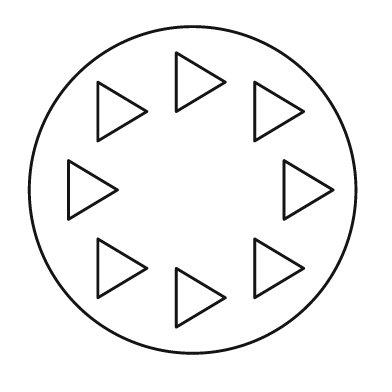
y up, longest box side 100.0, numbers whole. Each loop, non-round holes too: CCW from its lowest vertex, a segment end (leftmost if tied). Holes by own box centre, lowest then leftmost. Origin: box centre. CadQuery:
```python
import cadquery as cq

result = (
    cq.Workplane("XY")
    .moveTo(0.0, 0.0)
    .circle(50.0)
    .moveTo(-5.0, -42.0)
    .lineTo(10.0, -33.0)
    .lineTo(-5.0, -24.0)
    .close()
    .moveTo(-29.0, -33.0)
    .lineTo(-14.0, -24.0)
    .lineTo(-29.0, -15.0)
    .close()
    .moveTo(19.0, -33.0)
    .lineTo(34.0, -24.0)
    .lineTo(19.0, -15.0)
    .close()
    .moveTo(-38.0, -9.0)
    .lineTo(-23.0, 0.0)
    .lineTo(-38.0, 9.0)
    .close()
    .moveTo(28.0, -9.0)
    .lineTo(43.0, 0.0)
    .lineTo(28.0, 9.0)
    .close()
    .moveTo(-29.0, 15.0)
    .lineTo(-14.0, 24.0)
    .lineTo(-29.0, 33.0)
    .close()
    .moveTo(19.0, 15.0)
    .lineTo(34.0, 24.0)
    .lineTo(19.0, 33.0)
    .close()
    .moveTo(-5.0, 24.0)
    .lineTo(10.0, 33.0)
    .lineTo(-5.0, 42.0)
    .close()
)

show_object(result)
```